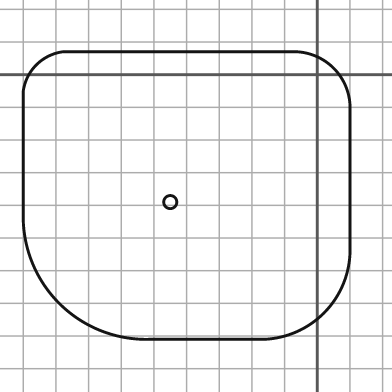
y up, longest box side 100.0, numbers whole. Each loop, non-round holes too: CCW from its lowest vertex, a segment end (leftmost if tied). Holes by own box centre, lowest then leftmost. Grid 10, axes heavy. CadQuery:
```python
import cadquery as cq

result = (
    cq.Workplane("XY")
    .moveTo(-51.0, -81.0)
    .lineTo(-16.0, -81.0)
    .threePointArc((2.0, -73.0), (10.0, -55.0))
    .lineTo(10.0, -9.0)
    .threePointArc((5.0, 2.0), (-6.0, 7.0))
    .lineTo(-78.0, 7.0)
    .threePointArc((-86.0, 3.0), (-90.0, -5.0))
    .lineTo(-90.0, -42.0)
    .threePointArc((-79.0, -70.0), (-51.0, -81.0))
    .close()
    .moveTo(-45.0, -39.0)
    .circle(2.0)
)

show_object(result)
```